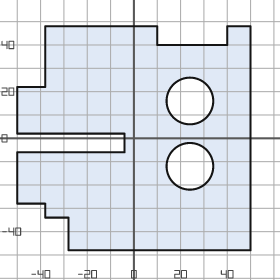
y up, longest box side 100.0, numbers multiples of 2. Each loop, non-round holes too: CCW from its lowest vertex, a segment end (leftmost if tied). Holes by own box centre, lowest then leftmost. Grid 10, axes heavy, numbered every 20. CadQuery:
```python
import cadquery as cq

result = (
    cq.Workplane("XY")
    .moveTo(-28.0, -48.0)
    .lineTo(50.0, -48.0)
    .lineTo(50.0, 48.0)
    .lineTo(40.0, 48.0)
    .lineTo(40.0, 40.0)
    .lineTo(10.0, 40.0)
    .lineTo(10.0, 48.0)
    .lineTo(-38.0, 48.0)
    .lineTo(-38.0, 22.0)
    .lineTo(-50.0, 22.0)
    .lineTo(-50.0, 2.0)
    .lineTo(-4.0, 2.0)
    .lineTo(-4.0, -6.0)
    .lineTo(-50.0, -6.0)
    .lineTo(-50.0, -28.0)
    .lineTo(-38.0, -28.0)
    .lineTo(-38.0, -34.0)
    .lineTo(-28.0, -34.0)
    .close()
    .moveTo(24.0, -12.0)
    .circle(10.0)
    .moveTo(24.0, 16.0)
    .circle(10.0)
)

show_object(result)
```